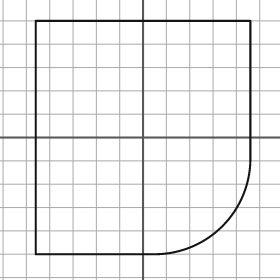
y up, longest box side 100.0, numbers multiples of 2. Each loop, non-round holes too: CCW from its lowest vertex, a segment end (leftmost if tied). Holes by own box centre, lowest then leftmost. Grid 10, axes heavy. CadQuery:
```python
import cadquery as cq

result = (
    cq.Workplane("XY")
    .moveTo(-46.0, -50.0)
    .lineTo(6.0, -50.0)
    .threePointArc((34.0, -38.0), (46.0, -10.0))
    .lineTo(46.0, 50.0)
    .lineTo(-46.0, 50.0)
    .close()
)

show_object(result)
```